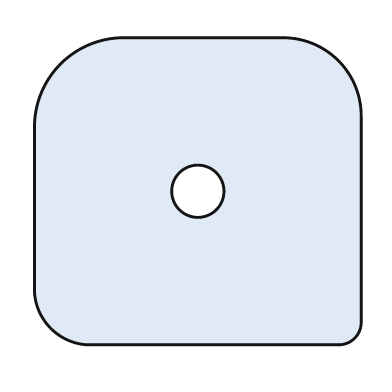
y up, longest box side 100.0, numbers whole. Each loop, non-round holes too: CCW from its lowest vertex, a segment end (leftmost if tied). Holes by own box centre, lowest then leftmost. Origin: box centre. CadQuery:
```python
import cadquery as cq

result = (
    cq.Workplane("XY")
    .moveTo(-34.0, -47.0)
    .lineTo(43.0, -47.0)
    .threePointArc((48.0, -45.0), (50.0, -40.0))
    .lineTo(50.0, 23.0)
    .threePointArc((43.0, 40.0), (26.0, 47.0))
    .lineTo(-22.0, 47.0)
    .threePointArc((-42.0, 39.0), (-50.0, 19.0))
    .lineTo(-50.0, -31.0)
    .threePointArc((-45.0, -42.0), (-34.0, -47.0))
    .close()
    .moveTo(0.0, 0.0)
    .circle(8.0)
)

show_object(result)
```